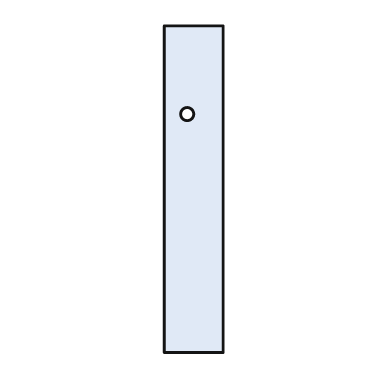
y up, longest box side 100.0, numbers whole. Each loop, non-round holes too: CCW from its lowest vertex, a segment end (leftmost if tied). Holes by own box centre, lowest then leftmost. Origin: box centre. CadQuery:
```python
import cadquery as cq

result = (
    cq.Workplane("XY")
    .moveTo(-9.0, -50.0)
    .lineTo(9.0, -50.0)
    .lineTo(9.0, 50.0)
    .lineTo(-9.0, 50.0)
    .close()
    .moveTo(-2.0, 23.0)
    .circle(2.0)
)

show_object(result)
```